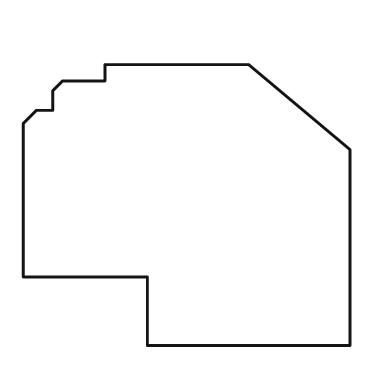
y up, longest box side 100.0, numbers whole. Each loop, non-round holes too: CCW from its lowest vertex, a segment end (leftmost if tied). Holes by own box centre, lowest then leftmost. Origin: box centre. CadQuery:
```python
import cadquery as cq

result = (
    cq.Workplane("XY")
    .moveTo(-12.0, -43.0)
    .lineTo(50.0, -43.0)
    .lineTo(50.0, 17.0)
    .lineTo(19.0, 43.0)
    .lineTo(-25.0, 43.0)
    .lineTo(-25.0, 38.0)
    .lineTo(-38.0, 38.0)
    .lineTo(-41.0, 35.0)
    .lineTo(-41.0, 29.0)
    .lineTo(-46.0, 29.0)
    .lineTo(-50.0, 25.0)
    .lineTo(-50.0, -22.0)
    .lineTo(-12.0, -22.0)
    .close()
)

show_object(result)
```